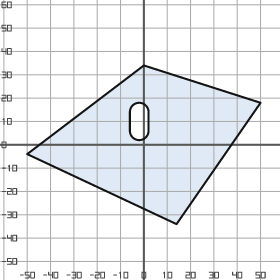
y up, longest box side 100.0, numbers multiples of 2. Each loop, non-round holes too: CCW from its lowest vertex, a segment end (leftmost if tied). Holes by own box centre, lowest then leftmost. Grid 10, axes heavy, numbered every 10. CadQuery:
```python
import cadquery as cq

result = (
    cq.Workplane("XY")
    .moveTo(14.0, -34.0)
    .lineTo(50.0, 18.0)
    .lineTo(0.0, 34.0)
    .lineTo(-50.0, -4.0)
    .close()
    .moveTo(-6.0, 6.0)
    .threePointArc((-2.0, 2.0), (2.0, 6.0))
    .lineTo(2.0, 14.0)
    .threePointArc((-2.0, 18.0), (-6.0, 14.0))
    .close()
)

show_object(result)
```